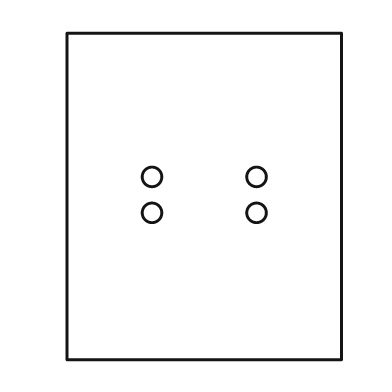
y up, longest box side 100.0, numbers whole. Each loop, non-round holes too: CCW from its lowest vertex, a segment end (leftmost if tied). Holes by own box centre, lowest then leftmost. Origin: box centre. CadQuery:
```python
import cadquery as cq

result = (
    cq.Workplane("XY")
    .moveTo(-42.0, -50.0)
    .lineTo(42.0, -50.0)
    .lineTo(42.0, 50.0)
    .lineTo(-42.0, 50.0)
    .close()
    .moveTo(-16.0, -5.0)
    .circle(3.0)
    .moveTo(16.0, -5.0)
    .circle(3.0)
    .moveTo(-16.0, 6.0)
    .circle(3.0)
    .moveTo(16.0, 6.0)
    .circle(3.0)
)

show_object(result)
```